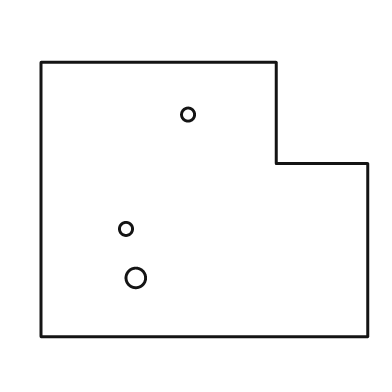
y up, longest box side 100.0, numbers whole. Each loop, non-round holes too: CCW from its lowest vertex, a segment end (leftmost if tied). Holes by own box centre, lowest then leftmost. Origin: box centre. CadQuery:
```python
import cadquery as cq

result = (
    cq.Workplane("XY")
    .moveTo(-50.0, -42.0)
    .lineTo(50.0, -42.0)
    .lineTo(50.0, 11.0)
    .lineTo(22.0, 11.0)
    .lineTo(22.0, 42.0)
    .lineTo(-50.0, 42.0)
    .close()
    .moveTo(-21.0, -24.0)
    .circle(3.0)
    .moveTo(-24.0, -9.0)
    .circle(2.0)
    .moveTo(-5.0, 26.0)
    .circle(2.0)
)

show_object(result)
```